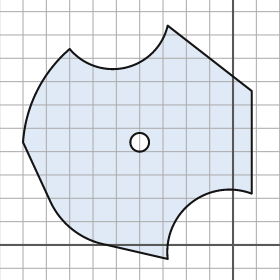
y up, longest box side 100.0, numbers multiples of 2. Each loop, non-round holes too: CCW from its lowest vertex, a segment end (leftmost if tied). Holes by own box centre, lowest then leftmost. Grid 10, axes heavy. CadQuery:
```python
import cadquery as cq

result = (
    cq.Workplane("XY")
    .moveTo(-28.0, -6.0)
    .threePointArc((-18.0, 18.0), (8.0, 22.0))
    .lineTo(8.0, 66.0)
    .lineTo(-28.0, 94.0)
    .threePointArc((-46.0, 76.0), (-70.0, 84.0))
    .threePointArc((-84.0, 66.0), (-90.0, 44.0))
    .lineTo(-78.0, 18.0)
    .threePointArc((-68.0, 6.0), (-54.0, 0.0))
    .close()
    .moveTo(-40.0, 44.0)
    .circle(4.0)
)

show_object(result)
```